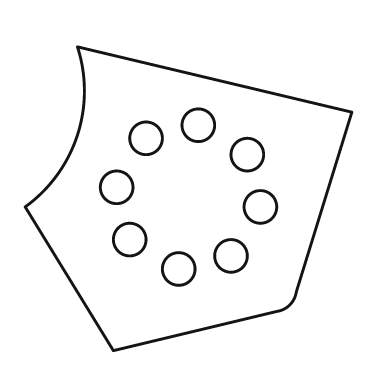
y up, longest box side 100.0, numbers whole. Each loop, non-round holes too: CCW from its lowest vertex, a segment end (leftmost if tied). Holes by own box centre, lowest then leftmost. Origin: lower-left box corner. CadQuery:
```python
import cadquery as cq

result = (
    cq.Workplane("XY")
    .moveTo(27.0, 0.0)
    .lineTo(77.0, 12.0)
    .threePointArc((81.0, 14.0), (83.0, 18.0))
    .lineTo(100.0, 73.0)
    .lineTo(16.0, 93.0)
    .threePointArc((16.0, 66.0), (0.0, 44.0))
    .close()
    .moveTo(47.0, 25.0)
    .circle(5.0)
    .moveTo(63.0, 29.0)
    .circle(5.0)
    .moveTo(32.0, 34.0)
    .circle(5.0)
    .moveTo(72.0, 44.0)
    .circle(5.0)
    .moveTo(28.0, 50.0)
    .circle(5.0)
    .moveTo(68.0, 60.0)
    .circle(5.0)
    .moveTo(37.0, 65.0)
    .circle(5.0)
    .moveTo(53.0, 69.0)
    .circle(5.0)
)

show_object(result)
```